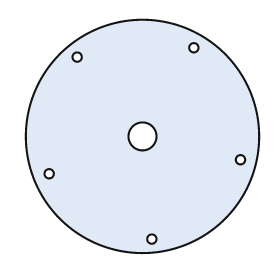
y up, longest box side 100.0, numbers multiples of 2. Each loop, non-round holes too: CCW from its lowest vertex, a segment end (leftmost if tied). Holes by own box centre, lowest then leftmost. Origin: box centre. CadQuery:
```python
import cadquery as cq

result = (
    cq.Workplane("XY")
    .moveTo(0.0, 0.0)
    .circle(50.0)
    .moveTo(4.0, -44.0)
    .circle(2.0)
    .moveTo(-40.0, -16.0)
    .circle(2.0)
    .moveTo(42.0, -10.0)
    .circle(2.0)
    .moveTo(0.0, 0.0)
    .circle(6.0)
    .moveTo(-28.0, 34.0)
    .circle(2.0)
    .moveTo(22.0, 38.0)
    .circle(2.0)
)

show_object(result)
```